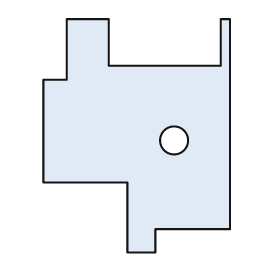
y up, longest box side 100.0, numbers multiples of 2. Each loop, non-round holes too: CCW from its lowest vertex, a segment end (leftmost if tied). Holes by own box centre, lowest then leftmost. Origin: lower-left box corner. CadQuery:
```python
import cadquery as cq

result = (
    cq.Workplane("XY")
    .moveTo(36.0, 0.0)
    .lineTo(48.0, 0.0)
    .lineTo(48.0, 10.0)
    .lineTo(80.0, 10.0)
    .lineTo(80.0, 100.0)
    .lineTo(76.0, 100.0)
    .lineTo(76.0, 80.0)
    .lineTo(28.0, 80.0)
    .lineTo(28.0, 100.0)
    .lineTo(10.0, 100.0)
    .lineTo(10.0, 74.0)
    .lineTo(0.0, 74.0)
    .lineTo(0.0, 30.0)
    .lineTo(36.0, 30.0)
    .close()
    .moveTo(56.0, 48.0)
    .circle(6.0)
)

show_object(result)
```